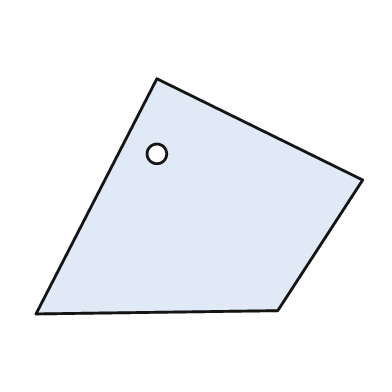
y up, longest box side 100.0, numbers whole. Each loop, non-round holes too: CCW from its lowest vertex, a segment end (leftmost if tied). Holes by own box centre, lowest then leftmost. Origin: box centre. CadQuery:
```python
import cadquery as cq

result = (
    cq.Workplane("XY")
    .moveTo(-50.0, -36.0)
    .lineTo(24.0, -35.0)
    .lineTo(50.0, 5.0)
    .lineTo(-13.0, 36.0)
    .close()
    .moveTo(-13.0, 13.0)
    .circle(3.0)
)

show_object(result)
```